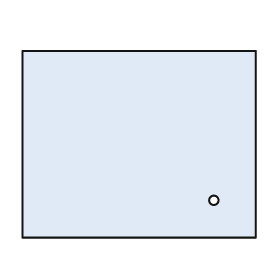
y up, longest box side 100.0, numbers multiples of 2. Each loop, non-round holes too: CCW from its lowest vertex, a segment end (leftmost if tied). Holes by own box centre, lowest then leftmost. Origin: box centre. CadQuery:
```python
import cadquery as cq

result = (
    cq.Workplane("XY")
    .moveTo(-50.0, -40.0)
    .lineTo(50.0, -40.0)
    .lineTo(50.0, 40.0)
    .lineTo(-50.0, 40.0)
    .close()
    .moveTo(32.0, -24.0)
    .circle(2.0)
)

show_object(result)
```